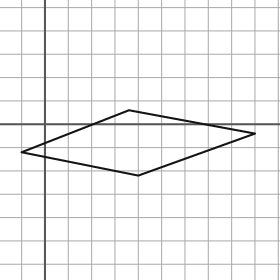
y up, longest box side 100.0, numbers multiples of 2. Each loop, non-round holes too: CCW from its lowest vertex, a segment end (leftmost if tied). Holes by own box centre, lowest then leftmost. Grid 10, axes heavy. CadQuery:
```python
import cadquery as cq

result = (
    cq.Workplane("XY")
    .moveTo(40.0, -22.0)
    .lineTo(90.0, -4.0)
    .lineTo(36.0, 6.0)
    .lineTo(-10.0, -12.0)
    .close()
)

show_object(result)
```